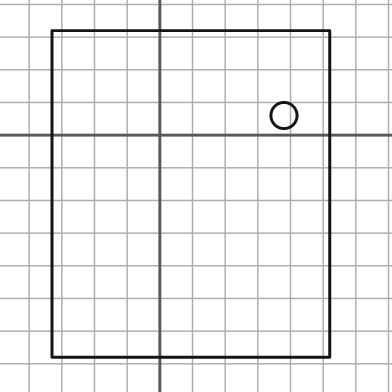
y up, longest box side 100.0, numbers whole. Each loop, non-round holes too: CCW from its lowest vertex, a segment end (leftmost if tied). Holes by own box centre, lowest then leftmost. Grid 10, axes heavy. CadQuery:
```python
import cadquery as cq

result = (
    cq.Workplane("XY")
    .moveTo(-33.0, -68.0)
    .lineTo(52.0, -68.0)
    .lineTo(52.0, 32.0)
    .lineTo(-33.0, 32.0)
    .close()
    .moveTo(38.0, 6.0)
    .circle(4.0)
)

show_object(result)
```